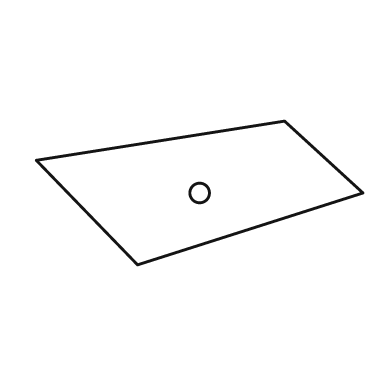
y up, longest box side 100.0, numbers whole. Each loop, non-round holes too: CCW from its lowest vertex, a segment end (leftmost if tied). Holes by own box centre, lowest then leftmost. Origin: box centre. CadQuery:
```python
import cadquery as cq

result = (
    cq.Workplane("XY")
    .moveTo(-19.0, -22.0)
    .lineTo(50.0, 0.0)
    .lineTo(26.0, 22.0)
    .lineTo(-50.0, 10.0)
    .close()
    .moveTo(0.0, 0.0)
    .circle(3.0)
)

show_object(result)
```